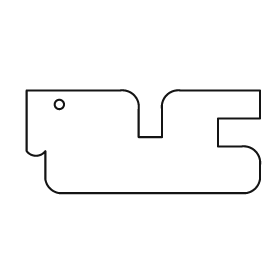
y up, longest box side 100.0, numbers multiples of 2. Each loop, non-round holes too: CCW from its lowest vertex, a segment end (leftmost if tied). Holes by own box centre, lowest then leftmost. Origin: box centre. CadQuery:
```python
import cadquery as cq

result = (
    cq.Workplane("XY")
    .moveTo(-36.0, -22.0)
    .lineTo(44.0, -22.0)
    .threePointArc((48.0, -20.0), (50.0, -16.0))
    .lineTo(50.0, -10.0)
    .threePointArc((48.0, -4.0), (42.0, -2.0))
    .lineTo(32.0, -2.0)
    .lineTo(32.0, 10.0)
    .lineTo(50.0, 10.0)
    .lineTo(50.0, 22.0)
    .lineTo(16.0, 22.0)
    .threePointArc((10.0, 20.0), (8.0, 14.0))
    .lineTo(8.0, 2.0)
    .lineTo(-2.0, 2.0)
    .lineTo(-2.0, 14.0)
    .threePointArc((-4.0, 20.0), (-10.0, 22.0))
    .lineTo(-50.0, 22.0)
    .lineTo(-50.0, -4.0)
    .threePointArc((-46.0, -6.0), (-42.0, -4.0))
    .lineTo(-42.0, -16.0)
    .threePointArc((-40.0, -20.0), (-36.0, -22.0))
    .close()
    .moveTo(-36.0, 16.0)
    .circle(2.0)
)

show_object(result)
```